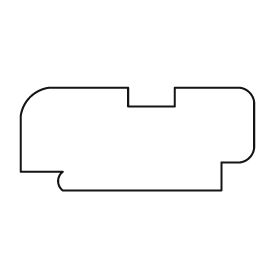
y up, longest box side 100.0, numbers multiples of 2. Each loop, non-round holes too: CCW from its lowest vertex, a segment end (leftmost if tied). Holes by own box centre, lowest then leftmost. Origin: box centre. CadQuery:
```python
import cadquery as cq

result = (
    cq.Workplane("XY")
    .moveTo(-32.0, -22.0)
    .lineTo(36.0, -22.0)
    .lineTo(36.0, -10.0)
    .lineTo(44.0, -10.0)
    .threePointArc((48.0, -8.0), (50.0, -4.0))
    .lineTo(50.0, 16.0)
    .threePointArc((48.0, 20.0), (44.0, 22.0))
    .lineTo(16.0, 22.0)
    .lineTo(16.0, 14.0)
    .lineTo(-4.0, 14.0)
    .lineTo(-4.0, 22.0)
    .lineTo(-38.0, 22.0)
    .threePointArc((-46.0, 18.0), (-50.0, 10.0))
    .lineTo(-50.0, -14.0)
    .lineTo(-32.0, -14.0)
    .threePointArc((-34.0, -18.0), (-32.0, -22.0))
    .close()
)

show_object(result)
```